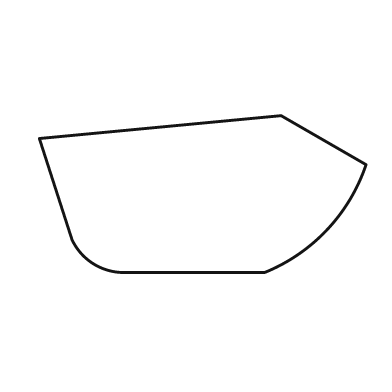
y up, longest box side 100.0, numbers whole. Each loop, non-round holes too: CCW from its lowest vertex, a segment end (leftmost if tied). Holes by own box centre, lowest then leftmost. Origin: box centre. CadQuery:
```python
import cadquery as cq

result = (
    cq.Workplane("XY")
    .moveTo(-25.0, -24.0)
    .lineTo(19.0, -24.0)
    .threePointArc((38.0, -11.0), (50.0, 9.0))
    .lineTo(24.0, 24.0)
    .lineTo(-50.0, 17.0)
    .lineTo(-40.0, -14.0)
    .threePointArc((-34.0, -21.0), (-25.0, -24.0))
    .close()
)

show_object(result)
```